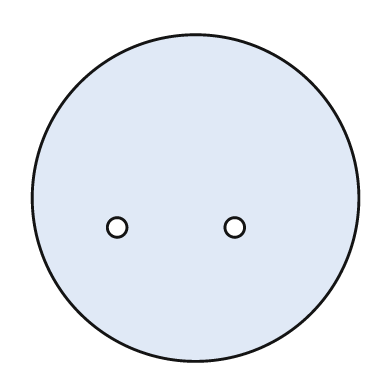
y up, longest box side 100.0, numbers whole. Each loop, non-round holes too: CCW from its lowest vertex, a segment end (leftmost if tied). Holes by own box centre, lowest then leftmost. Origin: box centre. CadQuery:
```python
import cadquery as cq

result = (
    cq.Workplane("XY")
    .moveTo(0.0, 0.0)
    .circle(50.0)
    .moveTo(-24.0, -9.0)
    .circle(3.0)
    .moveTo(12.0, -9.0)
    .circle(3.0)
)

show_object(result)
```